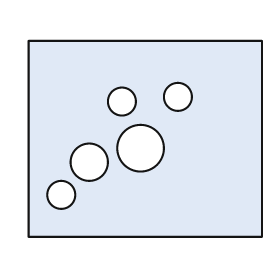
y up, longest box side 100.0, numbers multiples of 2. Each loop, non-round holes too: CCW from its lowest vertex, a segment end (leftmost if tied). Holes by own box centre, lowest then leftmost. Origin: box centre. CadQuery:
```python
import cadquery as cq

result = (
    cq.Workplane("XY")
    .moveTo(-50.0, -42.0)
    .lineTo(50.0, -42.0)
    .lineTo(50.0, 42.0)
    .lineTo(-50.0, 42.0)
    .close()
    .moveTo(-36.0, -24.0)
    .circle(6.0)
    .moveTo(-24.0, -10.0)
    .circle(8.0)
    .moveTo(-2.0, -4.0)
    .circle(10.0)
    .moveTo(-10.0, 16.0)
    .circle(6.0)
    .moveTo(14.0, 18.0)
    .circle(6.0)
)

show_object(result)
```